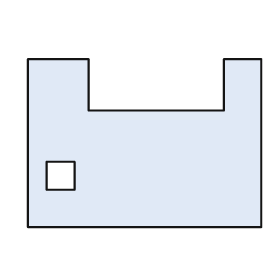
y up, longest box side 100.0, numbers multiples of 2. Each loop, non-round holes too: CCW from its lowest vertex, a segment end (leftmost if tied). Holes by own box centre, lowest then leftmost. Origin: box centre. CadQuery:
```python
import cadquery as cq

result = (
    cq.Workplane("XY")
    .moveTo(-50.0, -36.0)
    .lineTo(50.0, -36.0)
    .lineTo(50.0, 36.0)
    .lineTo(34.0, 36.0)
    .lineTo(34.0, 14.0)
    .lineTo(-24.0, 14.0)
    .lineTo(-24.0, 36.0)
    .lineTo(-50.0, 36.0)
    .close()
    .moveTo(-42.0, -20.0)
    .lineTo(-30.0, -20.0)
    .lineTo(-30.0, -8.0)
    .lineTo(-42.0, -8.0)
    .close()
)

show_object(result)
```